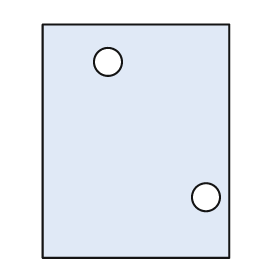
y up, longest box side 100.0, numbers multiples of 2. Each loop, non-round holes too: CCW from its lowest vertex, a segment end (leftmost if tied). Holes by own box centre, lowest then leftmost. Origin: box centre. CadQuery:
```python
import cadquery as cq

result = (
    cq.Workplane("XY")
    .moveTo(-40.0, -50.0)
    .lineTo(40.0, -50.0)
    .lineTo(40.0, 50.0)
    .lineTo(-40.0, 50.0)
    .close()
    .moveTo(30.0, -24.0)
    .circle(6.0)
    .moveTo(-12.0, 34.0)
    .circle(6.0)
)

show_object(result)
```